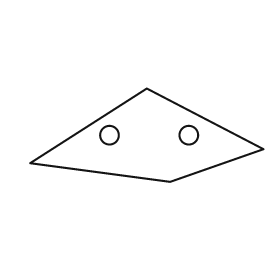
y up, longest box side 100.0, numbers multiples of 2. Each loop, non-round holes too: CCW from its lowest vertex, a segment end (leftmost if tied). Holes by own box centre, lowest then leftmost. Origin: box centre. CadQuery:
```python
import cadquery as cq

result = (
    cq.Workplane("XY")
    .moveTo(10.0, -20.0)
    .lineTo(50.0, -6.0)
    .lineTo(0.0, 20.0)
    .lineTo(-50.0, -12.0)
    .close()
    .moveTo(-16.0, 0.0)
    .circle(4.0)
    .moveTo(18.0, 0.0)
    .circle(4.0)
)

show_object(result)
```